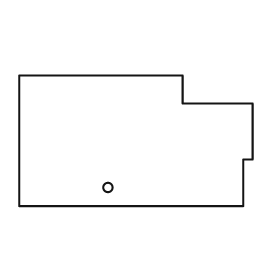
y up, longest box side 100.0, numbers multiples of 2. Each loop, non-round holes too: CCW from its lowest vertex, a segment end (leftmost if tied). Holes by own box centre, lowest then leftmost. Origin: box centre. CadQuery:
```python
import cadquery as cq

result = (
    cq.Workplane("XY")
    .moveTo(-50.0, -28.0)
    .lineTo(46.0, -28.0)
    .lineTo(46.0, -8.0)
    .lineTo(50.0, -8.0)
    .lineTo(50.0, 16.0)
    .lineTo(20.0, 16.0)
    .lineTo(20.0, 28.0)
    .lineTo(-50.0, 28.0)
    .close()
    .moveTo(-12.0, -20.0)
    .circle(2.0)
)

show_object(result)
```